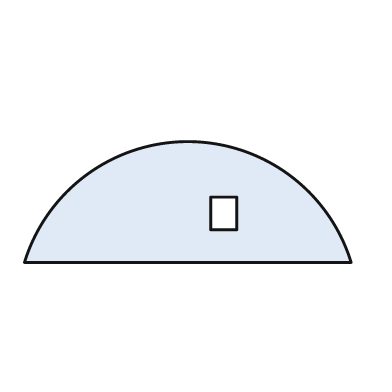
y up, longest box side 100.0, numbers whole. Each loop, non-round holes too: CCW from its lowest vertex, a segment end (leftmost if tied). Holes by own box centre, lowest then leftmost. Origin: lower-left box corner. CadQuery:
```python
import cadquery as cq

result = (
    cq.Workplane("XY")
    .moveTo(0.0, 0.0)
    .lineTo(100.0, 0.0)
    .threePointArc((50.0, 37.0), (0.0, 0.0))
    .close()
    .moveTo(57.0, 10.0)
    .lineTo(65.0, 10.0)
    .lineTo(65.0, 20.0)
    .lineTo(57.0, 20.0)
    .close()
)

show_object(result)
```